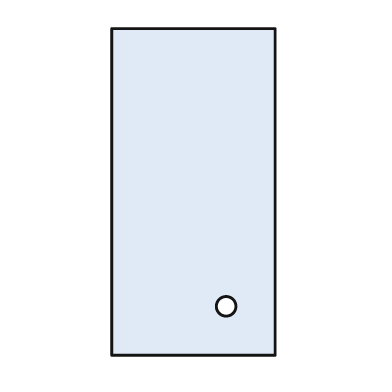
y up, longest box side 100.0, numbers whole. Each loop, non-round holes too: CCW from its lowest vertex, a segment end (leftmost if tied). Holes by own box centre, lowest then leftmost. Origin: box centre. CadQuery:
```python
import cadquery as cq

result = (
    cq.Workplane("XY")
    .moveTo(-25.0, -50.0)
    .lineTo(25.0, -50.0)
    .lineTo(25.0, 50.0)
    .lineTo(-25.0, 50.0)
    .close()
    .moveTo(10.0, -35.0)
    .circle(3.0)
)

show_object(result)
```